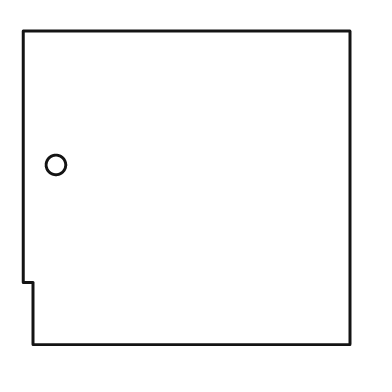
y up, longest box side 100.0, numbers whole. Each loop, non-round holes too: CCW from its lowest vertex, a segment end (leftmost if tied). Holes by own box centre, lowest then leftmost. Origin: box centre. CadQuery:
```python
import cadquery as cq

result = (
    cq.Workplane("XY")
    .moveTo(-47.0, -48.0)
    .lineTo(50.0, -48.0)
    .lineTo(50.0, 48.0)
    .lineTo(-50.0, 48.0)
    .lineTo(-50.0, -29.0)
    .lineTo(-47.0, -29.0)
    .close()
    .moveTo(-40.0, 7.0)
    .circle(3.0)
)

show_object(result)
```